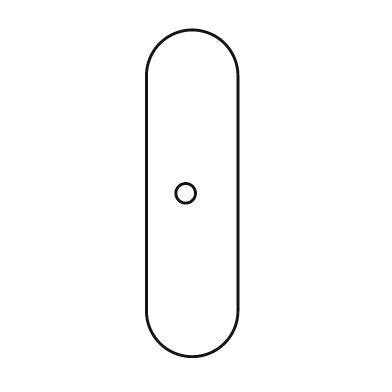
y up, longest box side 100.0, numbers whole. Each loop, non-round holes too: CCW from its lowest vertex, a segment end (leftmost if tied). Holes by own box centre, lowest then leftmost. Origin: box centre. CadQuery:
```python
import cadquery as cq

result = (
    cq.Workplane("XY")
    .moveTo(-14.0, -36.0)
    .threePointArc((0.0, -50.0), (14.0, -36.0))
    .lineTo(14.0, 36.0)
    .threePointArc((0.0, 50.0), (-14.0, 36.0))
    .close()
    .moveTo(-2.0, 0.0)
    .circle(3.0)
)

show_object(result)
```